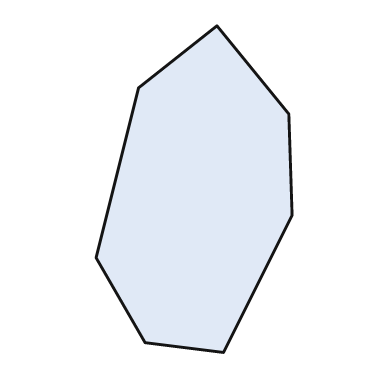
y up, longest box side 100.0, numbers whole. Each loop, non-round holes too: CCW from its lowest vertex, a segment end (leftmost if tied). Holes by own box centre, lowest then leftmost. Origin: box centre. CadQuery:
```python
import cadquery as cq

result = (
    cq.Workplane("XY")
    .moveTo(9.0, -50.0)
    .lineTo(30.0, -8.0)
    .lineTo(29.0, 23.0)
    .lineTo(7.0, 50.0)
    .lineTo(-17.0, 31.0)
    .lineTo(-30.0, -21.0)
    .lineTo(-15.0, -47.0)
    .close()
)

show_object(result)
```